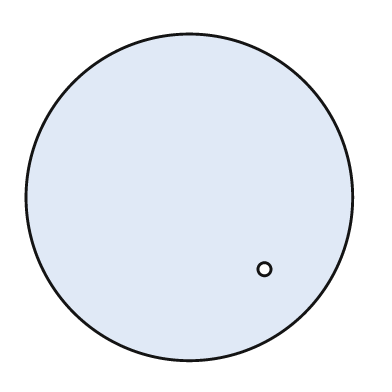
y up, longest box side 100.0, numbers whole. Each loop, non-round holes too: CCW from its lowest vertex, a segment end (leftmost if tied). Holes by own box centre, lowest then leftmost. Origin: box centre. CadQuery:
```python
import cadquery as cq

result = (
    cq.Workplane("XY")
    .moveTo(0.0, 0.0)
    .circle(50.0)
    .moveTo(23.0, -22.0)
    .circle(2.0)
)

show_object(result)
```